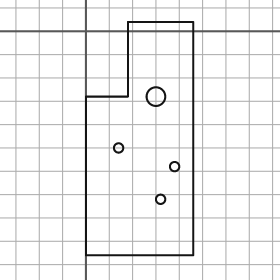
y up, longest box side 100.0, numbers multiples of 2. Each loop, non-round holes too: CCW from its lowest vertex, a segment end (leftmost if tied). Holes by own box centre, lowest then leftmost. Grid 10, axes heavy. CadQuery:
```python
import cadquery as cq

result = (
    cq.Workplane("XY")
    .moveTo(0.0, -96.0)
    .lineTo(46.0, -96.0)
    .lineTo(46.0, 4.0)
    .lineTo(18.0, 4.0)
    .lineTo(18.0, -28.0)
    .lineTo(0.0, -28.0)
    .close()
    .moveTo(32.0, -72.0)
    .circle(2.0)
    .moveTo(38.0, -58.0)
    .circle(2.0)
    .moveTo(14.0, -50.0)
    .circle(2.0)
    .moveTo(30.0, -28.0)
    .circle(4.0)
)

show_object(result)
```